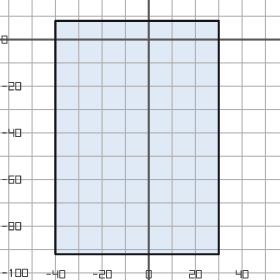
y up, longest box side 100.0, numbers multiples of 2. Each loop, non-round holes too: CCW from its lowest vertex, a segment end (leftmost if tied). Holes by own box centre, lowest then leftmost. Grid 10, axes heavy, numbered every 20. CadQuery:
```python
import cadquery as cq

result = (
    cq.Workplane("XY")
    .moveTo(-40.0, -92.0)
    .lineTo(30.0, -92.0)
    .lineTo(30.0, 8.0)
    .lineTo(-40.0, 8.0)
    .close()
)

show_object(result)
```